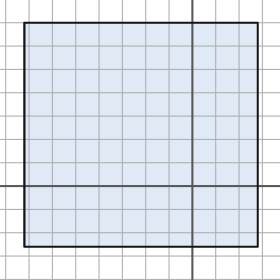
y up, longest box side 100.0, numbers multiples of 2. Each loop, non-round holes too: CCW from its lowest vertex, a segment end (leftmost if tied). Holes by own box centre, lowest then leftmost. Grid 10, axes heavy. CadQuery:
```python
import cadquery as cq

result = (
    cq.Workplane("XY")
    .moveTo(-72.0, -26.0)
    .lineTo(28.0, -26.0)
    .lineTo(28.0, 70.0)
    .lineTo(-72.0, 70.0)
    .close()
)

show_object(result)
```